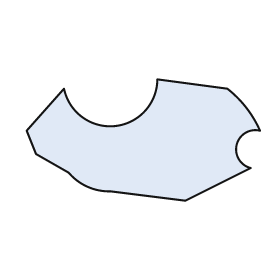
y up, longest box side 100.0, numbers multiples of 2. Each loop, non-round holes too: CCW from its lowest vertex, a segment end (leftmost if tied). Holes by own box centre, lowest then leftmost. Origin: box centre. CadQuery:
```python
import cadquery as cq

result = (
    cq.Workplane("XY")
    .moveTo(18.0, -26.0)
    .lineTo(46.0, -12.0)
    .threePointArc((40.0, -2.0), (50.0, 4.0))
    .threePointArc((44.0, 14.0), (36.0, 22.0))
    .lineTo(6.0, 26.0)
    .threePointArc((-12.0, 6.0), (-34.0, 22.0))
    .lineTo(-50.0, 4.0)
    .lineTo(-46.0, -6.0)
    .lineTo(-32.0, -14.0)
    .threePointArc((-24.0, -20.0), (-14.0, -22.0))
    .close()
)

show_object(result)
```